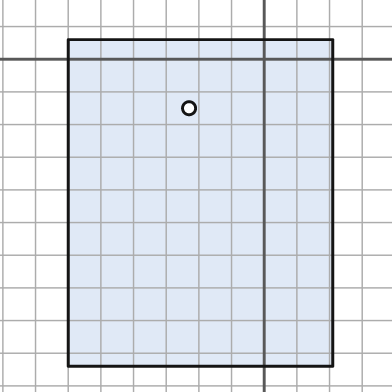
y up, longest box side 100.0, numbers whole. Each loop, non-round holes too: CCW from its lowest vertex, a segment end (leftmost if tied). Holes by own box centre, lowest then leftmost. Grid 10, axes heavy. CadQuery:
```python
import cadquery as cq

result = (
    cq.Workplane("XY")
    .moveTo(-60.0, -94.0)
    .lineTo(21.0, -94.0)
    .lineTo(21.0, 6.0)
    .lineTo(-60.0, 6.0)
    .close()
    .moveTo(-23.0, -15.0)
    .circle(2.0)
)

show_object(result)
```